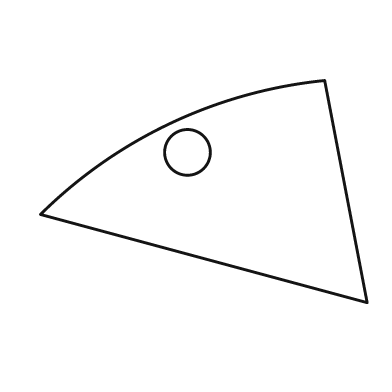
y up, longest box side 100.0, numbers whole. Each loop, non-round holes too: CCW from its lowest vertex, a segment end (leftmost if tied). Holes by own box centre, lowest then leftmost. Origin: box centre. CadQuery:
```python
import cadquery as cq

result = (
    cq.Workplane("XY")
    .moveTo(50.0, -34.0)
    .lineTo(37.0, 34.0)
    .threePointArc((-10.0, 21.0), (-50.0, -7.0))
    .close()
    .moveTo(-5.0, 12.0)
    .circle(7.0)
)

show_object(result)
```